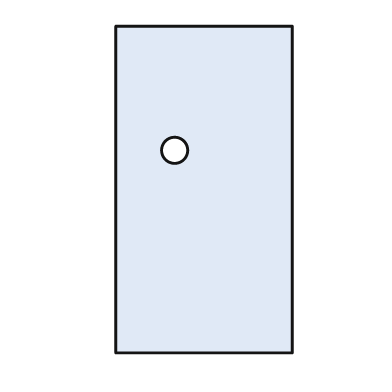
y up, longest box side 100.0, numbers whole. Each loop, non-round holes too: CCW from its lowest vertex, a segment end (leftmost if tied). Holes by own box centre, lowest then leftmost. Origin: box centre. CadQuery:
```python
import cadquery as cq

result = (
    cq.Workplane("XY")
    .moveTo(-27.0, -50.0)
    .lineTo(27.0, -50.0)
    .lineTo(27.0, 50.0)
    .lineTo(-27.0, 50.0)
    .close()
    .moveTo(-9.0, 12.0)
    .circle(4.0)
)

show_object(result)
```